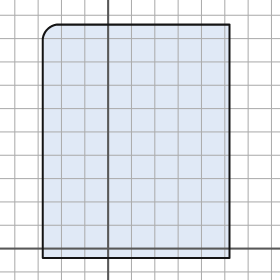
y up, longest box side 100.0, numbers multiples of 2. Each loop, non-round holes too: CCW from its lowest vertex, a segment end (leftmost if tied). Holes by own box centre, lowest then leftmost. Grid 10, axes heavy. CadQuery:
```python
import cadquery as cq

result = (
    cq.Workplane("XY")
    .moveTo(-28.0, -4.0)
    .lineTo(52.0, -4.0)
    .lineTo(52.0, 96.0)
    .lineTo(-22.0, 96.0)
    .threePointArc((-26.0, 94.0), (-28.0, 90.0))
    .close()
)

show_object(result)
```